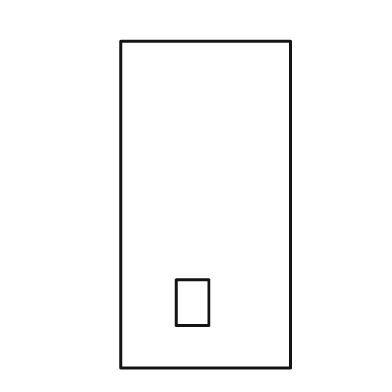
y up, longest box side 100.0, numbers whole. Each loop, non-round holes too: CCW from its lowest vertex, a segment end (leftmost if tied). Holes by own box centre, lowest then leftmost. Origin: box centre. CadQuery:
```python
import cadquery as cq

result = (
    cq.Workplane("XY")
    .moveTo(-26.0, -50.0)
    .lineTo(26.0, -50.0)
    .lineTo(26.0, 50.0)
    .lineTo(-26.0, 50.0)
    .close()
    .moveTo(-9.0, -37.0)
    .lineTo(1.0, -37.0)
    .lineTo(1.0, -23.0)
    .lineTo(-9.0, -23.0)
    .close()
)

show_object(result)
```